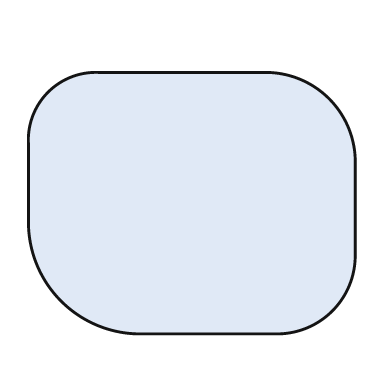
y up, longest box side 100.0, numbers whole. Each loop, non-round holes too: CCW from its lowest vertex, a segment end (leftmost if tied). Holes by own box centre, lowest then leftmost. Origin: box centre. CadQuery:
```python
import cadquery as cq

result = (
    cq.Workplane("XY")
    .moveTo(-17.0, -40.0)
    .lineTo(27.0, -40.0)
    .threePointArc((43.0, -33.0), (50.0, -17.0))
    .lineTo(50.0, 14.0)
    .threePointArc((42.0, 32.0), (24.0, 40.0))
    .lineTo(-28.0, 40.0)
    .threePointArc((-44.0, 34.0), (-50.0, 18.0))
    .lineTo(-50.0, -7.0)
    .threePointArc((-40.0, -30.0), (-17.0, -40.0))
    .close()
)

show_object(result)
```